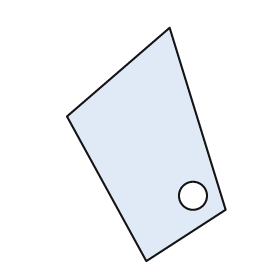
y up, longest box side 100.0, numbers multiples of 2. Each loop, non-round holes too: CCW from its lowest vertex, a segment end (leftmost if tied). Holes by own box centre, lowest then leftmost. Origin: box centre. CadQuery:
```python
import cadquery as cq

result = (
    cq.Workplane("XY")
    .moveTo(0.0, -50.0)
    .lineTo(34.0, -28.0)
    .lineTo(10.0, 50.0)
    .lineTo(-34.0, 12.0)
    .close()
    .moveTo(20.0, -22.0)
    .circle(6.0)
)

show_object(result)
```